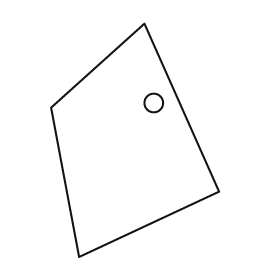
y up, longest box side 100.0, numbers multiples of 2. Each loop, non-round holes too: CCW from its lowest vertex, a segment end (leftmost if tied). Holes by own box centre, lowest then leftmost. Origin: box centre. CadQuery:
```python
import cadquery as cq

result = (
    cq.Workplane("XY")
    .moveTo(-24.0, -50.0)
    .lineTo(36.0, -22.0)
    .lineTo(4.0, 50.0)
    .lineTo(-36.0, 14.0)
    .close()
    .moveTo(8.0, 16.0)
    .circle(4.0)
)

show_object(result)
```